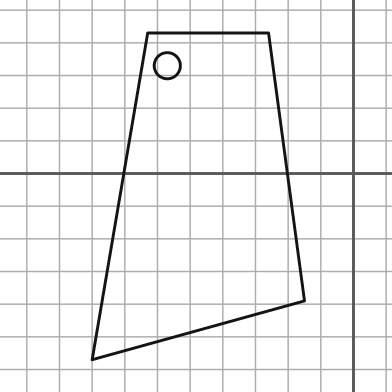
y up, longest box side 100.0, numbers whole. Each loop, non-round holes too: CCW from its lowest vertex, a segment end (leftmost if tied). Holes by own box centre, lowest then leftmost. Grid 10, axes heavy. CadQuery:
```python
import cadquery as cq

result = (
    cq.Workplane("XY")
    .moveTo(-80.0, -57.0)
    .lineTo(-15.0, -39.0)
    .lineTo(-26.0, 43.0)
    .lineTo(-63.0, 43.0)
    .close()
    .moveTo(-57.0, 33.0)
    .circle(4.0)
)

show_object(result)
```